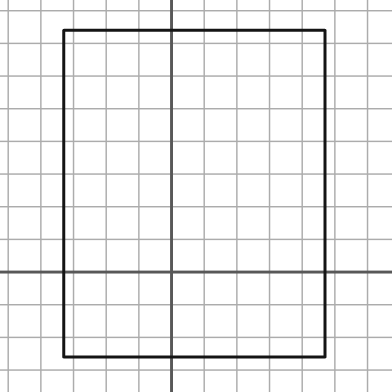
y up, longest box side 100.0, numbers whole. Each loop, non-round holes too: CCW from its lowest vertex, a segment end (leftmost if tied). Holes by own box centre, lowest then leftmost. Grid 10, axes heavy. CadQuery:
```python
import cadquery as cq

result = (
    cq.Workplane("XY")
    .moveTo(-33.0, -26.0)
    .lineTo(47.0, -26.0)
    .lineTo(47.0, 74.0)
    .lineTo(-33.0, 74.0)
    .close()
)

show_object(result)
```